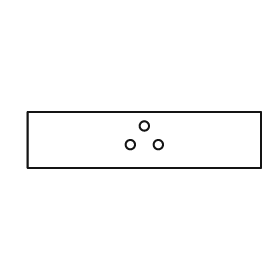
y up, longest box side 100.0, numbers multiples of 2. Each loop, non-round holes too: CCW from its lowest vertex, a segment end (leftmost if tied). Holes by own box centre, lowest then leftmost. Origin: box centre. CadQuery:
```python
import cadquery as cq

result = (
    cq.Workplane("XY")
    .moveTo(-50.0, -12.0)
    .lineTo(50.0, -12.0)
    .lineTo(50.0, 12.0)
    .lineTo(-50.0, 12.0)
    .close()
    .moveTo(-6.0, -2.0)
    .circle(2.0)
    .moveTo(6.0, -2.0)
    .circle(2.0)
    .moveTo(0.0, 6.0)
    .circle(2.0)
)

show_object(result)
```